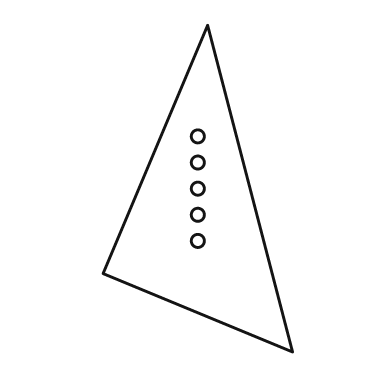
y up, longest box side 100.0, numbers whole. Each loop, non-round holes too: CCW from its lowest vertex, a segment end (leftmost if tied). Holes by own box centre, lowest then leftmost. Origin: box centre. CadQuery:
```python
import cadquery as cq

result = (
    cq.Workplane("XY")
    .moveTo(29.0, -50.0)
    .lineTo(3.0, 50.0)
    .lineTo(-29.0, -26.0)
    .close()
    .moveTo(0.0, -16.0)
    .circle(2.0)
    .moveTo(0.0, -8.0)
    .circle(2.0)
    .moveTo(0.0, 0.0)
    .circle(2.0)
    .moveTo(0.0, 8.0)
    .circle(2.0)
    .moveTo(0.0, 16.0)
    .circle(2.0)
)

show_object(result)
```